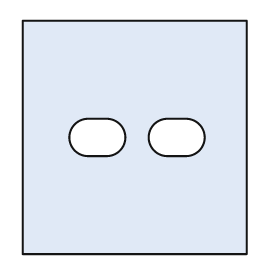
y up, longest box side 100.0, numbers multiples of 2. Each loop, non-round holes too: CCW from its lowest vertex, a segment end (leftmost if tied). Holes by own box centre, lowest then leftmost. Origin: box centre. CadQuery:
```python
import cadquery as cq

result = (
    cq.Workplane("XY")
    .moveTo(-48.0, -50.0)
    .lineTo(48.0, -50.0)
    .lineTo(48.0, 50.0)
    .lineTo(-48.0, 50.0)
    .close()
    .moveTo(-20.0, -8.0)
    .lineTo(-12.0, -8.0)
    .threePointArc((-4.0, 0.0), (-12.0, 8.0))
    .lineTo(-20.0, 8.0)
    .threePointArc((-28.0, 0.0), (-20.0, -8.0))
    .close()
    .moveTo(14.0, -8.0)
    .lineTo(22.0, -8.0)
    .threePointArc((30.0, 0.0), (22.0, 8.0))
    .lineTo(14.0, 8.0)
    .threePointArc((6.0, 0.0), (14.0, -8.0))
    .close()
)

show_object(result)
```